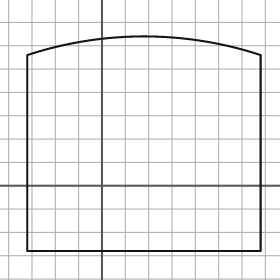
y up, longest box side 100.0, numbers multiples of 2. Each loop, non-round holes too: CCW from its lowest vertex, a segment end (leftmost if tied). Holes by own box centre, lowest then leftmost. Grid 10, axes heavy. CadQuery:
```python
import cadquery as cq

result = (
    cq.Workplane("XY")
    .moveTo(-32.0, -28.0)
    .lineTo(68.0, -28.0)
    .lineTo(68.0, 56.0)
    .threePointArc((18.0, 64.0), (-32.0, 56.0))
    .close()
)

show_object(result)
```